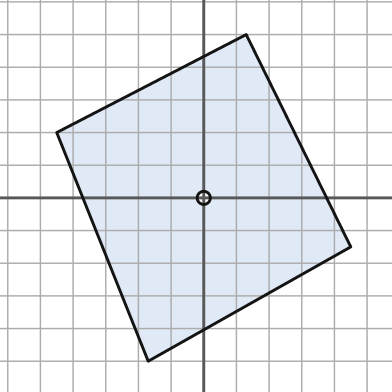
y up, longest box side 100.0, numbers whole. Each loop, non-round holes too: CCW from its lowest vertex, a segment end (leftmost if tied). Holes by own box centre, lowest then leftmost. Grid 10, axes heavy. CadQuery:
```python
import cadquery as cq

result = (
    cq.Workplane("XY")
    .moveTo(-17.0, -50.0)
    .lineTo(45.0, -15.0)
    .lineTo(13.0, 50.0)
    .lineTo(-45.0, 20.0)
    .close()
    .moveTo(0.0, 0.0)
    .circle(2.0)
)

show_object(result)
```